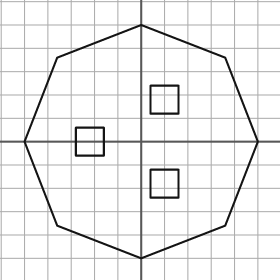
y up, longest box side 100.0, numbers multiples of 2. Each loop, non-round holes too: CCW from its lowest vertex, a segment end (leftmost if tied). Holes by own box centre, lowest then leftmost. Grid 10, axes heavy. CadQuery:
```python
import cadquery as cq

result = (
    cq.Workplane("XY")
    .moveTo(0.0, -50.0)
    .lineTo(36.0, -36.0)
    .lineTo(50.0, 0.0)
    .lineTo(36.0, 36.0)
    .lineTo(0.0, 50.0)
    .lineTo(-36.0, 36.0)
    .lineTo(-50.0, 0.0)
    .lineTo(-36.0, -36.0)
    .close()
    .moveTo(4.0, -24.0)
    .lineTo(16.0, -24.0)
    .lineTo(16.0, -12.0)
    .lineTo(4.0, -12.0)
    .close()
    .moveTo(-28.0, -6.0)
    .lineTo(-16.0, -6.0)
    .lineTo(-16.0, 6.0)
    .lineTo(-28.0, 6.0)
    .close()
    .moveTo(4.0, 12.0)
    .lineTo(16.0, 12.0)
    .lineTo(16.0, 24.0)
    .lineTo(4.0, 24.0)
    .close()
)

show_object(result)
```